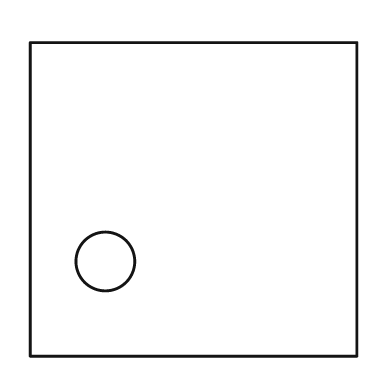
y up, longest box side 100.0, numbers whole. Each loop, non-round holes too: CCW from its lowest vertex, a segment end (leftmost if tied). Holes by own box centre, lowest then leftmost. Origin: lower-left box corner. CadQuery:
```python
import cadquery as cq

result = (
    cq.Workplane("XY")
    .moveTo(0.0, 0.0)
    .lineTo(100.0, 0.0)
    .lineTo(100.0, 96.0)
    .lineTo(0.0, 96.0)
    .close()
    .moveTo(23.0, 29.0)
    .circle(9.0)
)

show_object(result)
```